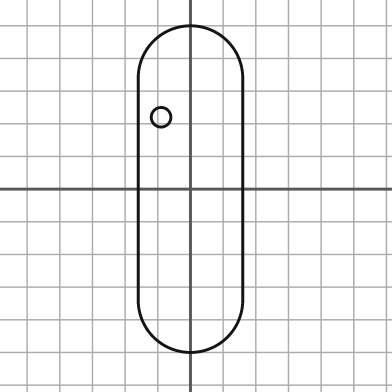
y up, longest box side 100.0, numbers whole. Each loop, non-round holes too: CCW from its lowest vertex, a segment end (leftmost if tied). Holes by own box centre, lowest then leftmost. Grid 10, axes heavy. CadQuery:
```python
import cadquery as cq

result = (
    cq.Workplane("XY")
    .moveTo(-16.0, -34.0)
    .threePointArc((0.0, -50.0), (16.0, -34.0))
    .lineTo(16.0, 34.0)
    .threePointArc((0.0, 50.0), (-16.0, 34.0))
    .close()
    .moveTo(-9.0, 22.0)
    .circle(3.0)
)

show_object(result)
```